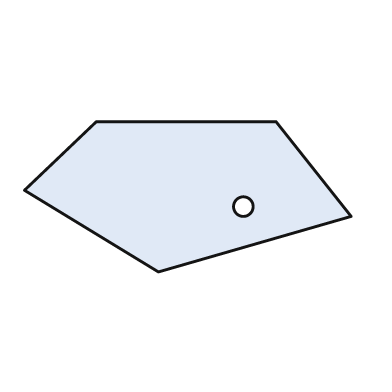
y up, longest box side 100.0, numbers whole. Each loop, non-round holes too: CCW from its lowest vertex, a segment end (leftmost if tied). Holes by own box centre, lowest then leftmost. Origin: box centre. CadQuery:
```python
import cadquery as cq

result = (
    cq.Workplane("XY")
    .moveTo(-9.0, -23.0)
    .lineTo(50.0, -6.0)
    .lineTo(27.0, 23.0)
    .lineTo(-28.0, 23.0)
    .lineTo(-50.0, 2.0)
    .close()
    .moveTo(17.0, -3.0)
    .circle(3.0)
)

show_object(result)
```